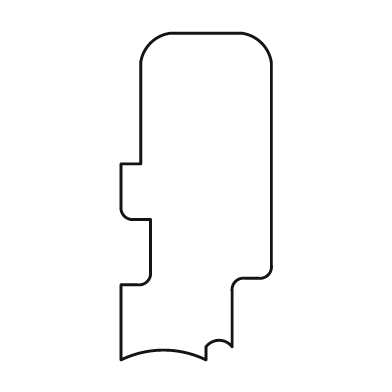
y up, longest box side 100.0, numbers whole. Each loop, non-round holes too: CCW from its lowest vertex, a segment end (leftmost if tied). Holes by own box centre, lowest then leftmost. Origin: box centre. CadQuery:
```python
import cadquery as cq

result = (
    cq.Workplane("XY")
    .moveTo(-23.0, -50.0)
    .threePointArc((-10.0, -47.0), (3.0, -50.0))
    .lineTo(3.0, -46.0)
    .threePointArc((7.0, -44.0), (11.0, -46.0))
    .lineTo(11.0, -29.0)
    .threePointArc((12.0, -26.0), (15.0, -25.0))
    .lineTo(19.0, -25.0)
    .threePointArc((22.0, -24.0), (23.0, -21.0))
    .lineTo(23.0, 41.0)
    .threePointArc((20.0, 47.0), (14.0, 50.0))
    .lineTo(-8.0, 50.0)
    .threePointArc((-14.0, 47.0), (-17.0, 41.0))
    .lineTo(-17.0, 10.0)
    .lineTo(-23.0, 10.0)
    .lineTo(-23.0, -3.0)
    .threePointArc((-22.0, -6.0), (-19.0, -7.0))
    .lineTo(-14.0, -7.0)
    .lineTo(-14.0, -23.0)
    .threePointArc((-15.0, -26.0), (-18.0, -27.0))
    .lineTo(-23.0, -27.0)
    .close()
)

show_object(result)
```